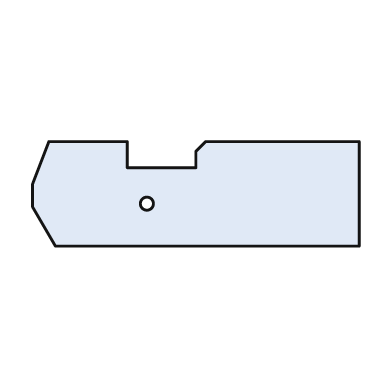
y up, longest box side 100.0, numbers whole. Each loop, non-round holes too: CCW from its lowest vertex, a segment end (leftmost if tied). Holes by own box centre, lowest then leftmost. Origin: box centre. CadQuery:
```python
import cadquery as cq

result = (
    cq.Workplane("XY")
    .moveTo(-43.0, -16.0)
    .lineTo(50.0, -16.0)
    .lineTo(50.0, 16.0)
    .lineTo(3.0, 16.0)
    .lineTo(0.0, 13.0)
    .lineTo(0.0, 8.0)
    .lineTo(-21.0, 8.0)
    .lineTo(-21.0, 16.0)
    .lineTo(-45.0, 16.0)
    .lineTo(-50.0, 3.0)
    .lineTo(-50.0, -4.0)
    .close()
    .moveTo(-15.0, -3.0)
    .circle(2.0)
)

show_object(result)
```